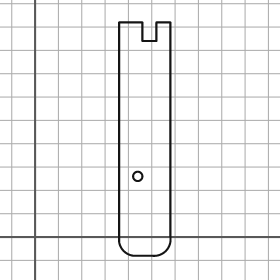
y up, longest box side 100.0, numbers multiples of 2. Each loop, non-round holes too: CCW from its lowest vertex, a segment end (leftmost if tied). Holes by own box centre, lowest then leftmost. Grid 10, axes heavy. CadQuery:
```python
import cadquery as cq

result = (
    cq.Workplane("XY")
    .moveTo(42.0, -8.0)
    .lineTo(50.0, -8.0)
    .threePointArc((56.0, -6.0), (58.0, 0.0))
    .lineTo(58.0, 92.0)
    .lineTo(52.0, 92.0)
    .lineTo(52.0, 84.0)
    .lineTo(46.0, 84.0)
    .lineTo(46.0, 92.0)
    .lineTo(36.0, 92.0)
    .lineTo(36.0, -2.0)
    .threePointArc((38.0, -6.0), (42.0, -8.0))
    .close()
    .moveTo(44.0, 26.0)
    .circle(2.0)
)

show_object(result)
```